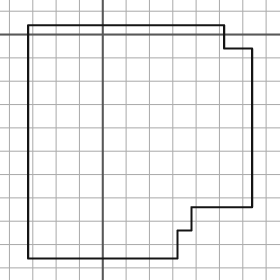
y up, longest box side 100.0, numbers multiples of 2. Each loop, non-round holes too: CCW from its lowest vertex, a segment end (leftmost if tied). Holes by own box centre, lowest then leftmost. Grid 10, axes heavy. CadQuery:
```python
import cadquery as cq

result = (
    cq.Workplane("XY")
    .moveTo(-32.0, -96.0)
    .lineTo(32.0, -96.0)
    .lineTo(32.0, -84.0)
    .lineTo(38.0, -84.0)
    .lineTo(38.0, -74.0)
    .lineTo(64.0, -74.0)
    .lineTo(64.0, -6.0)
    .lineTo(52.0, -6.0)
    .lineTo(52.0, 4.0)
    .lineTo(-32.0, 4.0)
    .close()
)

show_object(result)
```